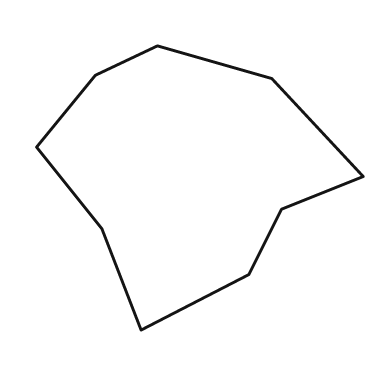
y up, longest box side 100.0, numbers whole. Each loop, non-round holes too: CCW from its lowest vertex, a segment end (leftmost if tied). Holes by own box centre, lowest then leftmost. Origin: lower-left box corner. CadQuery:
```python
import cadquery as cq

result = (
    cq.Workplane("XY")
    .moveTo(32.0, 0.0)
    .lineTo(65.0, 17.0)
    .lineTo(75.0, 37.0)
    .lineTo(100.0, 47.0)
    .lineTo(72.0, 77.0)
    .lineTo(37.0, 87.0)
    .lineTo(18.0, 78.0)
    .lineTo(0.0, 56.0)
    .lineTo(20.0, 31.0)
    .close()
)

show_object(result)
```